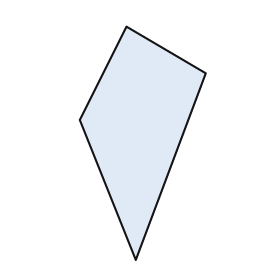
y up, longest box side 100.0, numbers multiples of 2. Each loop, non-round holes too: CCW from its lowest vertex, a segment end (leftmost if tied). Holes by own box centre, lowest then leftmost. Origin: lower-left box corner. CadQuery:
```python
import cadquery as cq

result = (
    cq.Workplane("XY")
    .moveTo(24.0, 0.0)
    .lineTo(54.0, 80.0)
    .lineTo(20.0, 100.0)
    .lineTo(0.0, 60.0)
    .close()
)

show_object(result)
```